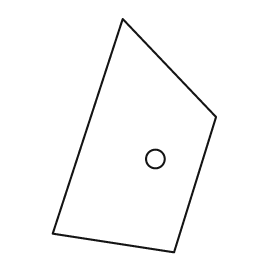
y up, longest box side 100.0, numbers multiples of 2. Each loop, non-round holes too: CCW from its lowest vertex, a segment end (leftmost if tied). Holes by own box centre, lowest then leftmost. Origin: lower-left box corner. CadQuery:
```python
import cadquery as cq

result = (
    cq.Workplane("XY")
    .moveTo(52.0, 0.0)
    .lineTo(70.0, 58.0)
    .lineTo(30.0, 100.0)
    .lineTo(0.0, 8.0)
    .close()
    .moveTo(44.0, 40.0)
    .circle(4.0)
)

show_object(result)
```